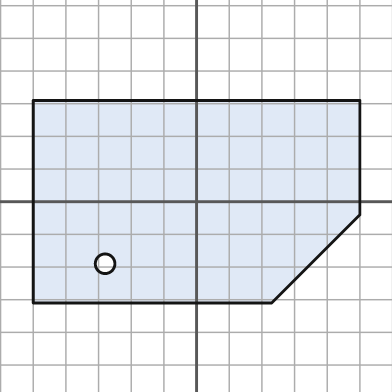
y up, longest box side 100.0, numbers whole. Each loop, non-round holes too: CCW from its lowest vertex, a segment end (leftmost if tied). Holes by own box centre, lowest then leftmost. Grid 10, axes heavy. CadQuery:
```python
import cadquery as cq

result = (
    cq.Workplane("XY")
    .moveTo(-50.0, -31.0)
    .lineTo(23.0, -31.0)
    .lineTo(50.0, -4.0)
    .lineTo(50.0, 31.0)
    .lineTo(-50.0, 31.0)
    .close()
    .moveTo(-28.0, -19.0)
    .circle(3.0)
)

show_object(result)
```